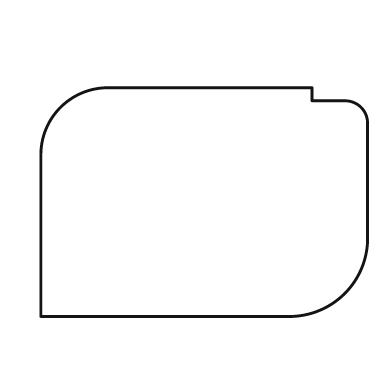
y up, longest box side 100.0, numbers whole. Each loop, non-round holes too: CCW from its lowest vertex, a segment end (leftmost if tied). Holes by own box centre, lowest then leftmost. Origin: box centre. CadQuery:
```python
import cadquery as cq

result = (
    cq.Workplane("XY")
    .moveTo(-50.0, -35.0)
    .lineTo(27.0, -35.0)
    .threePointArc((43.0, -28.0), (50.0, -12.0))
    .lineTo(50.0, 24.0)
    .threePointArc((48.0, 29.0), (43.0, 31.0))
    .lineTo(33.0, 31.0)
    .lineTo(33.0, 35.0)
    .lineTo(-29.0, 35.0)
    .threePointArc((-44.0, 29.0), (-50.0, 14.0))
    .close()
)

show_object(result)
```